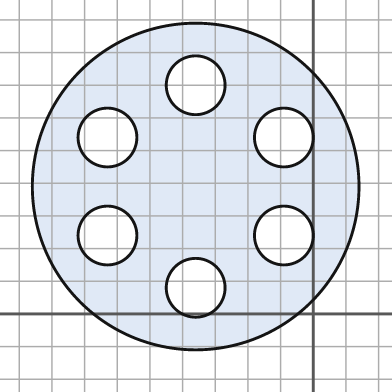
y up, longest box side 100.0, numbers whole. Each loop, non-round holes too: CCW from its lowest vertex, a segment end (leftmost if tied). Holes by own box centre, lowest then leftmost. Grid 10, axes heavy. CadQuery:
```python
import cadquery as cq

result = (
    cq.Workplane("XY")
    .moveTo(-36.0, 39.0)
    .circle(50.0)
    .moveTo(-36.0, 8.0)
    .circle(9.0)
    .moveTo(-63.0, 24.0)
    .circle(9.0)
    .moveTo(-9.0, 24.0)
    .circle(9.0)
    .moveTo(-63.0, 54.0)
    .circle(9.0)
    .moveTo(-9.0, 54.0)
    .circle(9.0)
    .moveTo(-36.0, 70.0)
    .circle(9.0)
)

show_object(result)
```